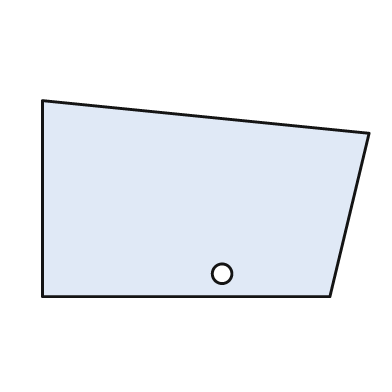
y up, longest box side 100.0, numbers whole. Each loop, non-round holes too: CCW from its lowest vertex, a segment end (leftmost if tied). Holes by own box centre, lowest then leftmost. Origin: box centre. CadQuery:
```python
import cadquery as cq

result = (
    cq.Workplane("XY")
    .moveTo(-50.0, -30.0)
    .lineTo(38.0, -30.0)
    .lineTo(50.0, 20.0)
    .lineTo(-50.0, 30.0)
    .close()
    .moveTo(5.0, -23.0)
    .circle(3.0)
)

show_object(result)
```